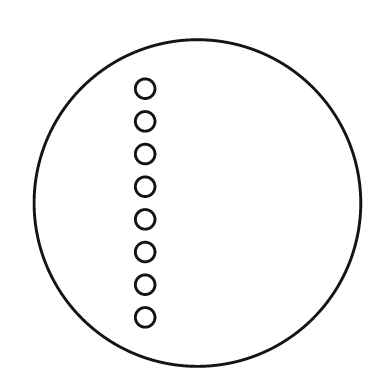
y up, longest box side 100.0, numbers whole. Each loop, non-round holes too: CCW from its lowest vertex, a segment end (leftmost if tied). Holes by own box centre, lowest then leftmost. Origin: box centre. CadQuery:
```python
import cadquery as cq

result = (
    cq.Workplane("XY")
    .moveTo(0.0, 0.0)
    .circle(50.0)
    .moveTo(-16.0, -35.0)
    .circle(3.0)
    .moveTo(-16.0, -25.0)
    .circle(3.0)
    .moveTo(-16.0, -15.0)
    .circle(3.0)
    .moveTo(-16.0, -5.0)
    .circle(3.0)
    .moveTo(-16.0, 5.0)
    .circle(3.0)
    .moveTo(-16.0, 15.0)
    .circle(3.0)
    .moveTo(-16.0, 25.0)
    .circle(3.0)
    .moveTo(-16.0, 35.0)
    .circle(3.0)
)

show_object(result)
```